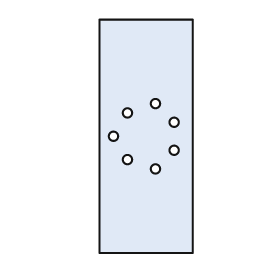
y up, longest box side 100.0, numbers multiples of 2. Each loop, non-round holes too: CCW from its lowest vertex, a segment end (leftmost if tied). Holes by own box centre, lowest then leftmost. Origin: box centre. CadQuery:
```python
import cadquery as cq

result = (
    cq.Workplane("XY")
    .moveTo(-20.0, -50.0)
    .lineTo(20.0, -50.0)
    .lineTo(20.0, 50.0)
    .lineTo(-20.0, 50.0)
    .close()
    .moveTo(4.0, -14.0)
    .circle(2.0)
    .moveTo(-8.0, -10.0)
    .circle(2.0)
    .moveTo(12.0, -6.0)
    .circle(2.0)
    .moveTo(-14.0, 0.0)
    .circle(2.0)
    .moveTo(12.0, 6.0)
    .circle(2.0)
    .moveTo(-8.0, 10.0)
    .circle(2.0)
    .moveTo(4.0, 14.0)
    .circle(2.0)
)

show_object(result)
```